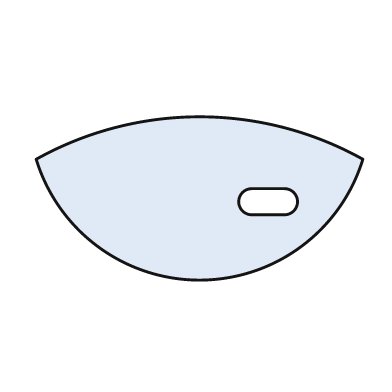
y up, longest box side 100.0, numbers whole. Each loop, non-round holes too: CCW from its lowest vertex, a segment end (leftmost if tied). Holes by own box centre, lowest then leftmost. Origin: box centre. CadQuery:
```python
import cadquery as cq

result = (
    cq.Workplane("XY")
    .moveTo(-50.0, 12.0)
    .threePointArc((0.0, -25.0), (50.0, 12.0))
    .threePointArc((0.0, 25.0), (-50.0, 12.0))
    .close()
    .moveTo(16.0, -5.0)
    .lineTo(26.0, -5.0)
    .threePointArc((30.0, -1.0), (26.0, 3.0))
    .lineTo(16.0, 3.0)
    .threePointArc((12.0, -1.0), (16.0, -5.0))
    .close()
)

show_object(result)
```